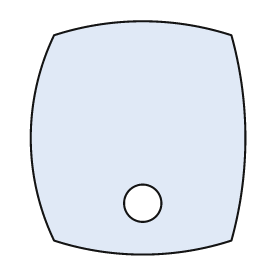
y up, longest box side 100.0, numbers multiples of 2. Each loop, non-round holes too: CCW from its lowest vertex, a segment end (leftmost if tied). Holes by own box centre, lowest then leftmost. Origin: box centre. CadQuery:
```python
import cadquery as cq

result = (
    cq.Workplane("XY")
    .moveTo(-36.0, -44.0)
    .threePointArc((2.0, -50.0), (40.0, -44.0))
    .threePointArc((46.0, 0.0), (40.0, 44.0))
    .threePointArc((2.0, 50.0), (-36.0, 44.0))
    .threePointArc((-46.0, 0.0), (-36.0, -44.0))
    .close()
    .moveTo(2.0, -28.0)
    .circle(8.0)
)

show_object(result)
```